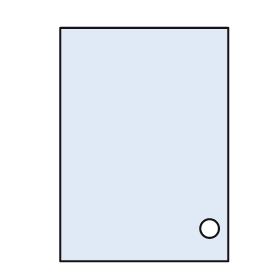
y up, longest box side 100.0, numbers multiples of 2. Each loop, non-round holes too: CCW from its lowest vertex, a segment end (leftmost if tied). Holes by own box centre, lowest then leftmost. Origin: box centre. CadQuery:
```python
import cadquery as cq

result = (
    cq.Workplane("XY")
    .moveTo(-36.0, -50.0)
    .lineTo(36.0, -50.0)
    .lineTo(36.0, 50.0)
    .lineTo(-36.0, 50.0)
    .close()
    .moveTo(28.0, -36.0)
    .circle(4.0)
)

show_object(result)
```